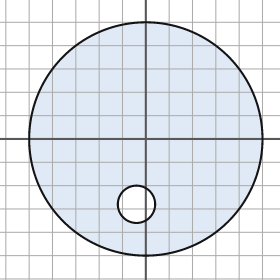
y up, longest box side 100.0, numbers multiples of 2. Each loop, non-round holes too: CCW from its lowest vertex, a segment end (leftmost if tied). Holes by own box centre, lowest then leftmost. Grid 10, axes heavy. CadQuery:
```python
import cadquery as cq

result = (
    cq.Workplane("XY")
    .moveTo(0.0, 0.0)
    .circle(50.0)
    .moveTo(-4.0, -28.0)
    .circle(8.0)
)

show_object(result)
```